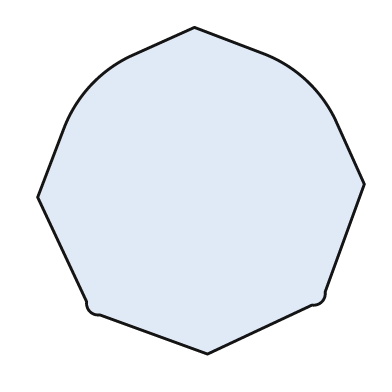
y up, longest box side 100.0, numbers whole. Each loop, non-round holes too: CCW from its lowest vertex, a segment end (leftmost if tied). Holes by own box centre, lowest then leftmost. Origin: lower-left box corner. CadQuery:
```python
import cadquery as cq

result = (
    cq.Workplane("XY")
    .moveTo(52.0, 0.0)
    .lineTo(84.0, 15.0)
    .threePointArc((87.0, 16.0), (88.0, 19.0))
    .lineTo(100.0, 52.0)
    .lineTo(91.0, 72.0)
    .threePointArc((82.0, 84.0), (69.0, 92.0))
    .lineTo(48.0, 100.0)
    .lineTo(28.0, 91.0)
    .threePointArc((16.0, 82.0), (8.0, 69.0))
    .lineTo(0.0, 48.0)
    .lineTo(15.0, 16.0)
    .threePointArc((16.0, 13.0), (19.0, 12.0))
    .close()
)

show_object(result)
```